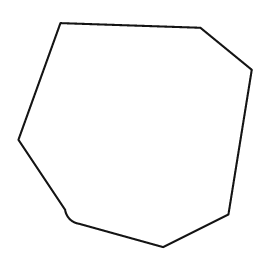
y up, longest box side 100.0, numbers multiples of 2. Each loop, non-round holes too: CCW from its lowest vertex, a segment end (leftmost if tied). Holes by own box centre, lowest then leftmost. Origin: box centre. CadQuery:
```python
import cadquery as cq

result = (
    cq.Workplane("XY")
    .moveTo(12.0, -48.0)
    .lineTo(40.0, -34.0)
    .lineTo(50.0, 28.0)
    .lineTo(28.0, 46.0)
    .lineTo(-32.0, 48.0)
    .lineTo(-50.0, -2.0)
    .lineTo(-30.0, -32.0)
    .threePointArc((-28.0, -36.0), (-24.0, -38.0))
    .close()
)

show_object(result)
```